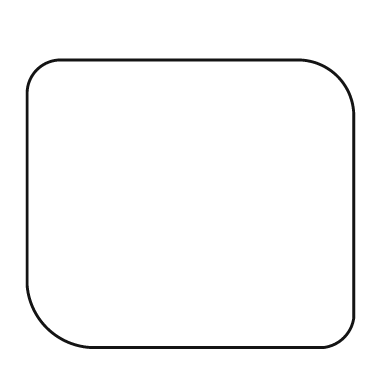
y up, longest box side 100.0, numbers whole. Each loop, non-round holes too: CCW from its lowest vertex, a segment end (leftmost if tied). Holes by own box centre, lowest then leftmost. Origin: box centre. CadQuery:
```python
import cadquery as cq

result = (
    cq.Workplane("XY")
    .moveTo(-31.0, -44.0)
    .lineTo(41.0, -44.0)
    .threePointArc((47.0, -41.0), (50.0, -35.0))
    .lineTo(50.0, 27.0)
    .threePointArc((45.0, 39.0), (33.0, 44.0))
    .lineTo(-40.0, 44.0)
    .threePointArc((-47.0, 41.0), (-50.0, 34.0))
    .lineTo(-50.0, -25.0)
    .threePointArc((-44.0, -38.0), (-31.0, -44.0))
    .close()
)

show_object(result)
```